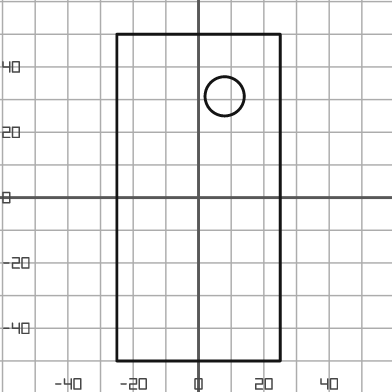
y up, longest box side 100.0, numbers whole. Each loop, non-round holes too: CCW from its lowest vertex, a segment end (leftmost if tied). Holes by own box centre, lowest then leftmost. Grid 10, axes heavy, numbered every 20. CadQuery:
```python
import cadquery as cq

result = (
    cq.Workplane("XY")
    .moveTo(-25.0, -50.0)
    .lineTo(25.0, -50.0)
    .lineTo(25.0, 50.0)
    .lineTo(-25.0, 50.0)
    .close()
    .moveTo(8.0, 31.0)
    .circle(6.0)
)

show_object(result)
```